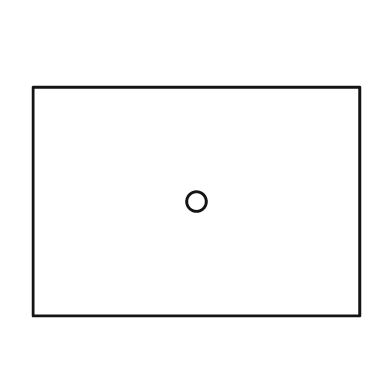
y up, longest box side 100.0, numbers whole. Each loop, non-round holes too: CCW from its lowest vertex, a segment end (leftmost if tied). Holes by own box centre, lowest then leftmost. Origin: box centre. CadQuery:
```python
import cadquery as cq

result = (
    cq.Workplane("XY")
    .moveTo(-50.0, -35.0)
    .lineTo(50.0, -35.0)
    .lineTo(50.0, 35.0)
    .lineTo(-50.0, 35.0)
    .close()
    .moveTo(0.0, 0.0)
    .circle(3.0)
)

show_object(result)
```